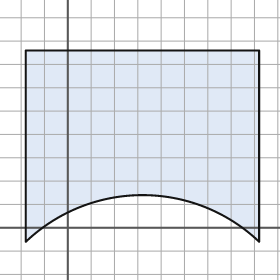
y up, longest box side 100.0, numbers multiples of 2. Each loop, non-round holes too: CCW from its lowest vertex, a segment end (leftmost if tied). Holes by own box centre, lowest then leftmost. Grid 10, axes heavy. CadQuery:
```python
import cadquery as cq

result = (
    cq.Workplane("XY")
    .moveTo(-18.0, -6.0)
    .threePointArc((32.0, 14.0), (82.0, -6.0))
    .lineTo(82.0, 76.0)
    .lineTo(-18.0, 76.0)
    .close()
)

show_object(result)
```